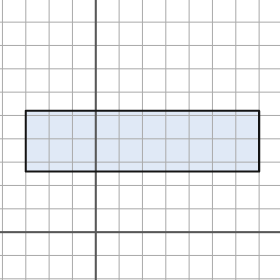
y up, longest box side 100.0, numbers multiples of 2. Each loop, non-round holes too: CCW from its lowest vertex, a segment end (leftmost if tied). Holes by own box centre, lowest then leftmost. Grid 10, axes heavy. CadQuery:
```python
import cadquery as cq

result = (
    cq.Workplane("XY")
    .moveTo(-30.0, 26.0)
    .lineTo(70.0, 26.0)
    .lineTo(70.0, 52.0)
    .lineTo(-30.0, 52.0)
    .close()
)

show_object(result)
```